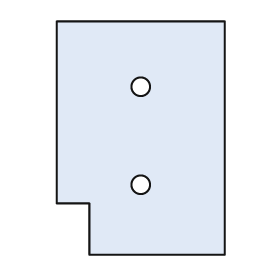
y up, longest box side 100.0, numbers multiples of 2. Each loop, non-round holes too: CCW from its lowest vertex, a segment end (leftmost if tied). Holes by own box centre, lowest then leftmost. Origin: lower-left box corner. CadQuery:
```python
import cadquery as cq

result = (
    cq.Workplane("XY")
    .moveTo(14.0, 0.0)
    .lineTo(72.0, 0.0)
    .lineTo(72.0, 100.0)
    .lineTo(0.0, 100.0)
    .lineTo(0.0, 22.0)
    .lineTo(14.0, 22.0)
    .close()
    .moveTo(36.0, 30.0)
    .circle(4.0)
    .moveTo(36.0, 72.0)
    .circle(4.0)
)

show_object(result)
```